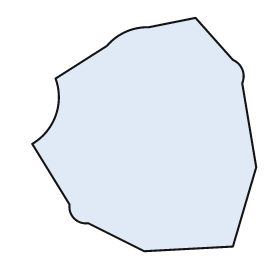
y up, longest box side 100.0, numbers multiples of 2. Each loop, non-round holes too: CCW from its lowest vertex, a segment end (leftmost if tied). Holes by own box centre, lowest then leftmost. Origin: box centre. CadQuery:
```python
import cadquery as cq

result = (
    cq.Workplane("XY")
    .moveTo(0.0, -50.0)
    .lineTo(38.0, -48.0)
    .lineTo(48.0, -14.0)
    .lineTo(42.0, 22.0)
    .threePointArc((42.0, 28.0), (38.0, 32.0))
    .lineTo(22.0, 50.0)
    .lineTo(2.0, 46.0)
    .threePointArc((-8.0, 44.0), (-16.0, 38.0))
    .lineTo(-38.0, 24.0)
    .threePointArc((-38.0, 8.0), (-48.0, -4.0))
    .lineTo(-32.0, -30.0)
    .threePointArc((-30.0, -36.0), (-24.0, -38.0))
    .close()
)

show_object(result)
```